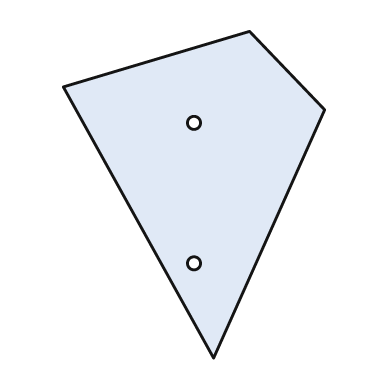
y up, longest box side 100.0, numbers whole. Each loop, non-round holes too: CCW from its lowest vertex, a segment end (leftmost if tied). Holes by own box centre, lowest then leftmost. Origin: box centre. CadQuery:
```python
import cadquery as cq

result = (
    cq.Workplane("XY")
    .moveTo(6.0, -50.0)
    .lineTo(40.0, 26.0)
    .lineTo(17.0, 50.0)
    .lineTo(-40.0, 33.0)
    .close()
    .moveTo(0.0, -21.0)
    .circle(2.0)
    .moveTo(0.0, 22.0)
    .circle(2.0)
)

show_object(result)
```